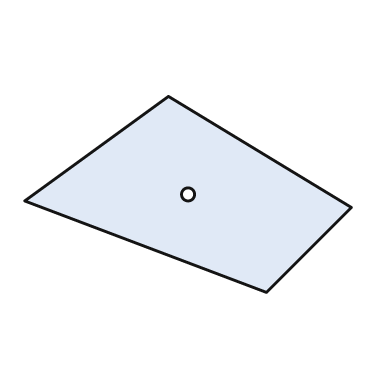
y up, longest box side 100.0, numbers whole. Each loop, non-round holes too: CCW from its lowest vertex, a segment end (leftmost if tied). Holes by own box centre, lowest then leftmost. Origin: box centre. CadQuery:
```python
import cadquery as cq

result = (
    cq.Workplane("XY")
    .moveTo(24.0, -30.0)
    .lineTo(50.0, -4.0)
    .lineTo(-6.0, 30.0)
    .lineTo(-50.0, -2.0)
    .close()
    .moveTo(0.0, 0.0)
    .circle(2.0)
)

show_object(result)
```